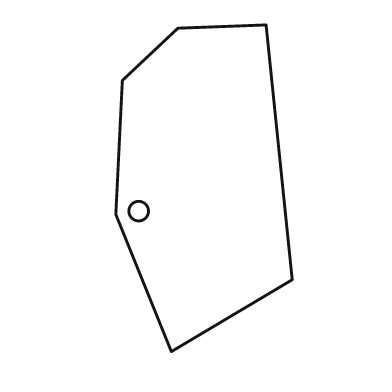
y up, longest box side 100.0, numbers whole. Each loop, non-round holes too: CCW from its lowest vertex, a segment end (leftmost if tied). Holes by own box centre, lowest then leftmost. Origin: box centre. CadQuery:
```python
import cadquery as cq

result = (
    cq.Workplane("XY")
    .moveTo(-10.0, -50.0)
    .lineTo(27.0, -28.0)
    .lineTo(19.0, 50.0)
    .lineTo(-8.0, 49.0)
    .lineTo(-25.0, 33.0)
    .lineTo(-27.0, -8.0)
    .close()
    .moveTo(-20.0, -7.0)
    .circle(3.0)
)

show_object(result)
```